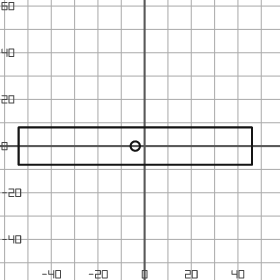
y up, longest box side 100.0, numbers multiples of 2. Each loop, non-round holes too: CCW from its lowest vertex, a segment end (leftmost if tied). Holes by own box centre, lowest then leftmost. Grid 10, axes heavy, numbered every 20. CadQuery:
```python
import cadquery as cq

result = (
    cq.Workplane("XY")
    .moveTo(-54.0, -8.0)
    .lineTo(46.0, -8.0)
    .lineTo(46.0, 8.0)
    .lineTo(-54.0, 8.0)
    .close()
    .moveTo(-4.0, 0.0)
    .circle(2.0)
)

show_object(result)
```